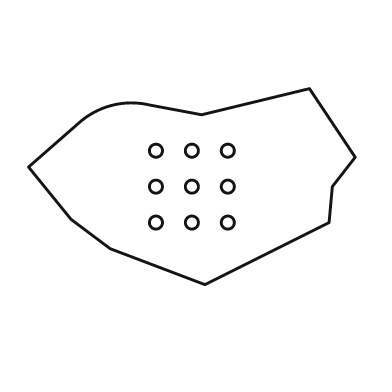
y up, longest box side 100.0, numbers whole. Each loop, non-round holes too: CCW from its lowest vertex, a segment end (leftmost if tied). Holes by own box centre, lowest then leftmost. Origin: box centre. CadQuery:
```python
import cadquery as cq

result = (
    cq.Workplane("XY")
    .moveTo(4.0, -30.0)
    .lineTo(42.0, -11.0)
    .lineTo(43.0, 0.0)
    .lineTo(50.0, 9.0)
    .lineTo(36.0, 30.0)
    .lineTo(3.0, 22.0)
    .lineTo(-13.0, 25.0)
    .threePointArc((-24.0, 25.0), (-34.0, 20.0))
    .lineTo(-50.0, 6.0)
    .lineTo(-37.0, -10.0)
    .lineTo(-25.0, -19.0)
    .close()
    .moveTo(-11.0, -11.0)
    .circle(2.0)
    .moveTo(0.0, -11.0)
    .circle(2.0)
    .moveTo(11.0, -11.0)
    .circle(2.0)
    .moveTo(-11.0, 0.0)
    .circle(2.0)
    .moveTo(0.0, 0.0)
    .circle(2.0)
    .moveTo(11.0, 0.0)
    .circle(2.0)
    .moveTo(-11.0, 11.0)
    .circle(2.0)
    .moveTo(0.0, 11.0)
    .circle(2.0)
    .moveTo(11.0, 11.0)
    .circle(2.0)
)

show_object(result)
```